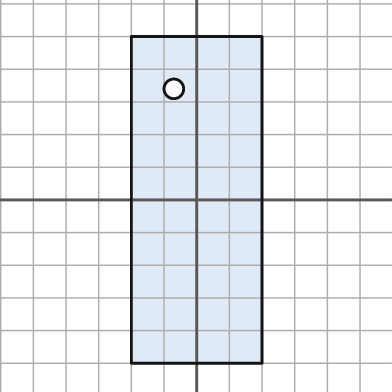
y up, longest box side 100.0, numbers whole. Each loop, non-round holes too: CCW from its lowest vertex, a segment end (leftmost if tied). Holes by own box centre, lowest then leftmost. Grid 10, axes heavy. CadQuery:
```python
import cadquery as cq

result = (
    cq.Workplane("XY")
    .moveTo(-20.0, -50.0)
    .lineTo(20.0, -50.0)
    .lineTo(20.0, 50.0)
    .lineTo(-20.0, 50.0)
    .close()
    .moveTo(-7.0, 34.0)
    .circle(3.0)
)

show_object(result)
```